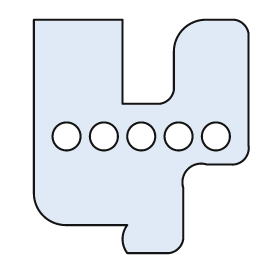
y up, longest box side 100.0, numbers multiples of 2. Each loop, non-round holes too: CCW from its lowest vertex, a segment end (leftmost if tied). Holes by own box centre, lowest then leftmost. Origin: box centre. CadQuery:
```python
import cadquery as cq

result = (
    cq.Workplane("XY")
    .moveTo(-6.0, -50.0)
    .lineTo(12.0, -50.0)
    .threePointArc((16.0, -48.0), (18.0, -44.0))
    .lineTo(18.0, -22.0)
    .threePointArc((20.0, -14.0), (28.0, -12.0))
    .lineTo(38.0, -12.0)
    .threePointArc((44.0, -10.0), (46.0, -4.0))
    .lineTo(46.0, 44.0)
    .threePointArc((44.0, 48.0), (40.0, 50.0))
    .lineTo(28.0, 50.0)
    .threePointArc((18.0, 46.0), (14.0, 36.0))
    .lineTo(14.0, 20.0)
    .threePointArc((12.0, 16.0), (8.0, 14.0))
    .lineTo(-8.0, 14.0)
    .lineTo(-8.0, 50.0)
    .lineTo(-46.0, 50.0)
    .lineTo(-46.0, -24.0)
    .threePointArc((-42.0, -34.0), (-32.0, -38.0))
    .lineTo(-6.0, -38.0)
    .threePointArc((-8.0, -44.0), (-6.0, -50.0))
    .close()
    .moveTo(-32.0, 0.0)
    .circle(6.0)
    .moveTo(-16.0, 0.0)
    .circle(6.0)
    .moveTo(0.0, 0.0)
    .circle(6.0)
    .moveTo(16.0, 0.0)
    .circle(6.0)
    .moveTo(32.0, 0.0)
    .circle(6.0)
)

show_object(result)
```